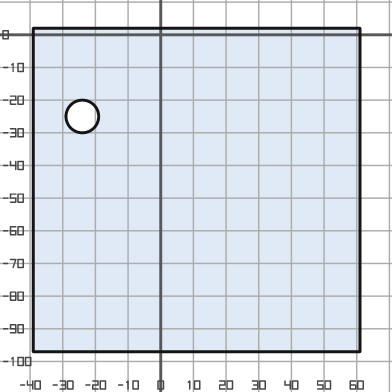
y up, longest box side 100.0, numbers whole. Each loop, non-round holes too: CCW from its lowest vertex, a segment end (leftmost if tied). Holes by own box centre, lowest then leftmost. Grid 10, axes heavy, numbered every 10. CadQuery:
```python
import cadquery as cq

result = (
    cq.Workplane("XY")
    .moveTo(-39.0, -97.0)
    .lineTo(61.0, -97.0)
    .lineTo(61.0, 2.0)
    .lineTo(-39.0, 2.0)
    .close()
    .moveTo(-24.0, -25.0)
    .circle(5.0)
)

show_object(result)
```